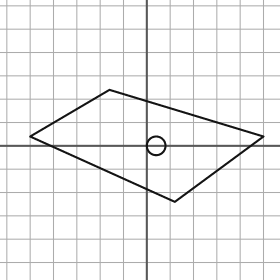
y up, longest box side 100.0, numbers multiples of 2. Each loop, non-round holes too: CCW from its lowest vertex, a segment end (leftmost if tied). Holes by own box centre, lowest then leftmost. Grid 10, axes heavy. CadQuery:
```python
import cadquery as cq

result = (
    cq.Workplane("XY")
    .moveTo(12.0, -24.0)
    .lineTo(50.0, 4.0)
    .lineTo(-16.0, 24.0)
    .lineTo(-50.0, 4.0)
    .close()
    .moveTo(4.0, 0.0)
    .circle(4.0)
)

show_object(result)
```